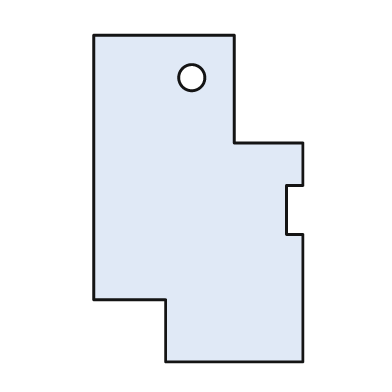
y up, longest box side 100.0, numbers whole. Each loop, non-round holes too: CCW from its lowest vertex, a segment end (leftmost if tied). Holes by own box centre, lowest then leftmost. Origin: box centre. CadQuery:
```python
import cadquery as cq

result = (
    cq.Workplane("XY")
    .moveTo(-10.0, -50.0)
    .lineTo(32.0, -50.0)
    .lineTo(32.0, -11.0)
    .lineTo(27.0, -11.0)
    .lineTo(27.0, 4.0)
    .lineTo(32.0, 4.0)
    .lineTo(32.0, 17.0)
    .lineTo(11.0, 17.0)
    .lineTo(11.0, 50.0)
    .lineTo(-32.0, 50.0)
    .lineTo(-32.0, -31.0)
    .lineTo(-10.0, -31.0)
    .close()
    .moveTo(-2.0, 37.0)
    .circle(4.0)
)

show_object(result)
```